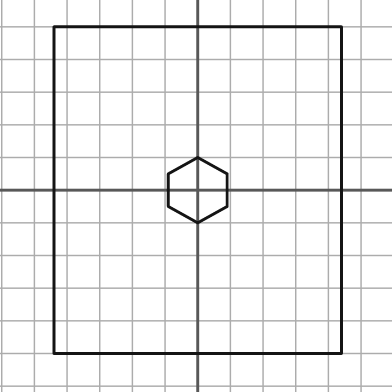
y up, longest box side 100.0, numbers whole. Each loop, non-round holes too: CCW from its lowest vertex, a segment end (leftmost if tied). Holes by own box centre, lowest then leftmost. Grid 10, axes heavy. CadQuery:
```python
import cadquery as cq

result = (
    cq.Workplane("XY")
    .moveTo(-44.0, -50.0)
    .lineTo(44.0, -50.0)
    .lineTo(44.0, 50.0)
    .lineTo(-44.0, 50.0)
    .close()
    .moveTo(0.0, -10.0)
    .lineTo(9.0, -5.0)
    .lineTo(9.0, 5.0)
    .lineTo(0.0, 10.0)
    .lineTo(-9.0, 5.0)
    .lineTo(-9.0, -5.0)
    .close()
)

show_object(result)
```